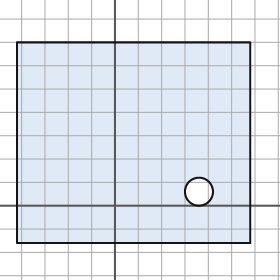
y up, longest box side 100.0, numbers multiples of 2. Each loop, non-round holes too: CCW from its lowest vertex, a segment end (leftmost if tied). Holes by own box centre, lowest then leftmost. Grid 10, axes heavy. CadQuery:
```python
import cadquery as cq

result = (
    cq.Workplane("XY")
    .moveTo(-42.0, -16.0)
    .lineTo(58.0, -16.0)
    .lineTo(58.0, 70.0)
    .lineTo(-42.0, 70.0)
    .close()
    .moveTo(36.0, 6.0)
    .circle(6.0)
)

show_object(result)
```